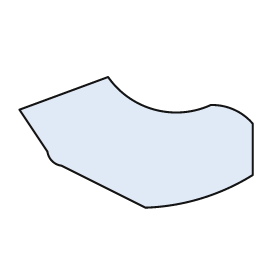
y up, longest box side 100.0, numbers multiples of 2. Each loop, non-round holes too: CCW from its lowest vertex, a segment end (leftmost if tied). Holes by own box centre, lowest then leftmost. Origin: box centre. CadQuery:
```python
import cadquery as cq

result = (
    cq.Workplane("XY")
    .moveTo(4.0, -28.0)
    .threePointArc((28.0, -24.0), (50.0, -14.0))
    .lineTo(50.0, 8.0)
    .threePointArc((42.0, 14.0), (32.0, 16.0))
    .threePointArc((8.0, 14.0), (-12.0, 28.0))
    .lineTo(-50.0, 14.0)
    .lineTo(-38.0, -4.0)
    .threePointArc((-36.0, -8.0), (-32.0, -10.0))
    .close()
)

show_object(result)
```